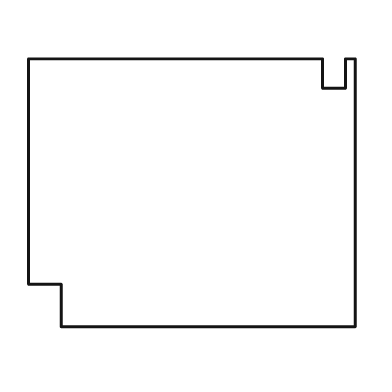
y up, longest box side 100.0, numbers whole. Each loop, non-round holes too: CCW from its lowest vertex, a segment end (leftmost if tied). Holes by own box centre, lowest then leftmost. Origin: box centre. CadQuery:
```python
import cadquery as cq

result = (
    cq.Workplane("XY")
    .moveTo(-40.0, -41.0)
    .lineTo(50.0, -41.0)
    .lineTo(50.0, 41.0)
    .lineTo(47.0, 41.0)
    .lineTo(47.0, 32.0)
    .lineTo(40.0, 32.0)
    .lineTo(40.0, 41.0)
    .lineTo(-50.0, 41.0)
    .lineTo(-50.0, -28.0)
    .lineTo(-40.0, -28.0)
    .close()
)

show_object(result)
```